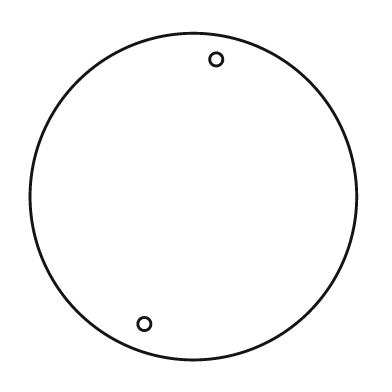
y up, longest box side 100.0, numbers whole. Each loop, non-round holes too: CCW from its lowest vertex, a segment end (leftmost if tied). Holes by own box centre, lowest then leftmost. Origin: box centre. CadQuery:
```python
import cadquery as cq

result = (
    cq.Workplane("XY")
    .moveTo(0.0, 0.0)
    .circle(50.0)
    .moveTo(-15.0, -39.0)
    .circle(2.0)
    .moveTo(7.0, 42.0)
    .circle(2.0)
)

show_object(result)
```